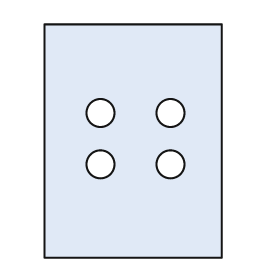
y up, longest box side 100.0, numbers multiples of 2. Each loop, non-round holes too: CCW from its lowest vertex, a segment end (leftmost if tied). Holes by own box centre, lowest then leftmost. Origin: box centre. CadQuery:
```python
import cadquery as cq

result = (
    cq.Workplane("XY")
    .moveTo(-38.0, -50.0)
    .lineTo(38.0, -50.0)
    .lineTo(38.0, 50.0)
    .lineTo(-38.0, 50.0)
    .close()
    .moveTo(-14.0, -10.0)
    .circle(6.0)
    .moveTo(16.0, -10.0)
    .circle(6.0)
    .moveTo(-14.0, 12.0)
    .circle(6.0)
    .moveTo(16.0, 12.0)
    .circle(6.0)
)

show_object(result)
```